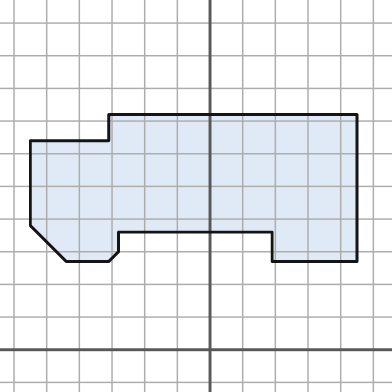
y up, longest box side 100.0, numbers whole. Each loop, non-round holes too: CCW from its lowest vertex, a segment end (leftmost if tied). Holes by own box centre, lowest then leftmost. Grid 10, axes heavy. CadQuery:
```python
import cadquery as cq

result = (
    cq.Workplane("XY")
    .moveTo(-44.0, 27.0)
    .lineTo(-31.0, 27.0)
    .lineTo(-28.0, 30.0)
    .lineTo(-28.0, 36.0)
    .lineTo(19.0, 36.0)
    .lineTo(19.0, 27.0)
    .lineTo(45.0, 27.0)
    .lineTo(45.0, 72.0)
    .lineTo(-31.0, 72.0)
    .lineTo(-31.0, 64.0)
    .lineTo(-55.0, 64.0)
    .lineTo(-55.0, 38.0)
    .close()
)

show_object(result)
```